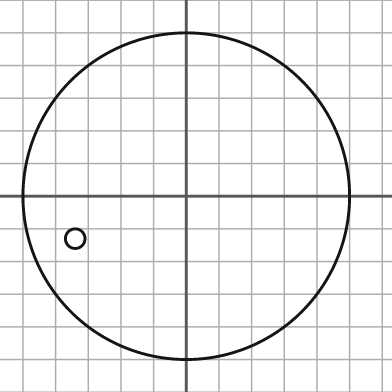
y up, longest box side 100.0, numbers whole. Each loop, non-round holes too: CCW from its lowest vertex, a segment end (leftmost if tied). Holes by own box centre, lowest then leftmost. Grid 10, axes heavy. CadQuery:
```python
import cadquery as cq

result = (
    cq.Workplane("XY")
    .moveTo(0.0, 0.0)
    .circle(50.0)
    .moveTo(-34.0, -13.0)
    .circle(3.0)
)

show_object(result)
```